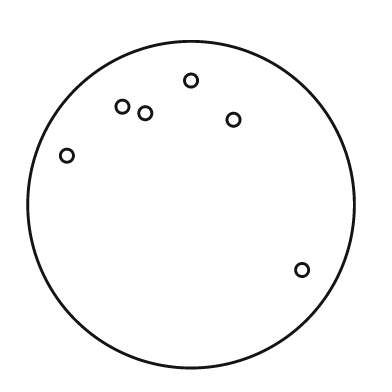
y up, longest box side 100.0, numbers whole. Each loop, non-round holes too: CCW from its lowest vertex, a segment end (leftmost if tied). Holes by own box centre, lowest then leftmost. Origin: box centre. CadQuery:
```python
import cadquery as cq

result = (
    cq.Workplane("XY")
    .moveTo(0.0, 0.0)
    .circle(50.0)
    .moveTo(34.0, -20.0)
    .circle(2.0)
    .moveTo(-38.0, 15.0)
    .circle(2.0)
    .moveTo(13.0, 26.0)
    .circle(2.0)
    .moveTo(-14.0, 28.0)
    .circle(2.0)
    .moveTo(-21.0, 30.0)
    .circle(2.0)
    .moveTo(0.0, 38.0)
    .circle(2.0)
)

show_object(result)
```